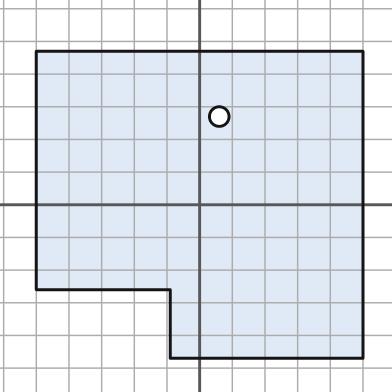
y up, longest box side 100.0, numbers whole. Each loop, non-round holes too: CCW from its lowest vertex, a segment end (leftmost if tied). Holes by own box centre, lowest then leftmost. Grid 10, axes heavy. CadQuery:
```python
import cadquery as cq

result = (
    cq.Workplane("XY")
    .moveTo(-9.0, -47.0)
    .lineTo(50.0, -47.0)
    .lineTo(50.0, 47.0)
    .lineTo(-50.0, 47.0)
    .lineTo(-50.0, -26.0)
    .lineTo(-9.0, -26.0)
    .close()
    .moveTo(6.0, 27.0)
    .circle(3.0)
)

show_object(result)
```